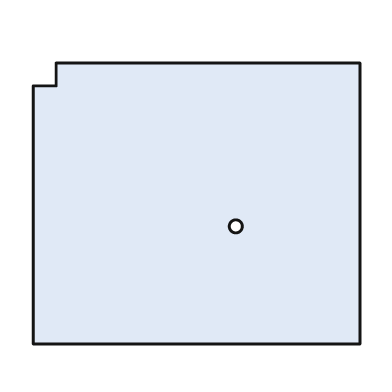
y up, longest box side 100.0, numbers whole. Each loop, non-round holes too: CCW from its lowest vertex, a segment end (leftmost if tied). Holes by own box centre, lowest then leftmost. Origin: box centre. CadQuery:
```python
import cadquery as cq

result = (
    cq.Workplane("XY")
    .moveTo(-50.0, -43.0)
    .lineTo(50.0, -43.0)
    .lineTo(50.0, 43.0)
    .lineTo(-43.0, 43.0)
    .lineTo(-43.0, 36.0)
    .lineTo(-50.0, 36.0)
    .close()
    .moveTo(12.0, -7.0)
    .circle(2.0)
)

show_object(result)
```